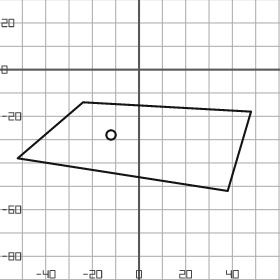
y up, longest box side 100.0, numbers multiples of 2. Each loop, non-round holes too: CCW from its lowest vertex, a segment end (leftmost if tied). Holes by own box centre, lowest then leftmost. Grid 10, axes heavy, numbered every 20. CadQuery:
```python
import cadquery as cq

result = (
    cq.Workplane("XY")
    .moveTo(38.0, -52.0)
    .lineTo(48.0, -18.0)
    .lineTo(-24.0, -14.0)
    .lineTo(-52.0, -38.0)
    .close()
    .moveTo(-12.0, -28.0)
    .circle(2.0)
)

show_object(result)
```